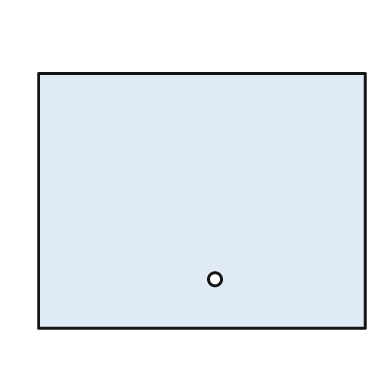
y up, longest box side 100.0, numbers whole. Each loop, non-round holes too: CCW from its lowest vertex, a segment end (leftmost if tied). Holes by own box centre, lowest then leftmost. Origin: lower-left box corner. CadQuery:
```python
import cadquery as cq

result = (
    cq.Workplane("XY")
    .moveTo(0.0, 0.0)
    .lineTo(100.0, 0.0)
    .lineTo(100.0, 78.0)
    .lineTo(0.0, 78.0)
    .close()
    .moveTo(54.0, 15.0)
    .circle(2.0)
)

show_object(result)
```